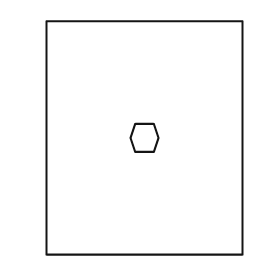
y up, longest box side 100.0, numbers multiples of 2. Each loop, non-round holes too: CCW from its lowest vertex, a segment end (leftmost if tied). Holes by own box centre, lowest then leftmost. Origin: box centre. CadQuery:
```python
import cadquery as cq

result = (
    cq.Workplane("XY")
    .moveTo(-42.0, -50.0)
    .lineTo(42.0, -50.0)
    .lineTo(42.0, 50.0)
    .lineTo(-42.0, 50.0)
    .close()
    .moveTo(-4.0, -6.0)
    .lineTo(4.0, -6.0)
    .lineTo(6.0, 0.0)
    .lineTo(4.0, 6.0)
    .lineTo(-4.0, 6.0)
    .lineTo(-6.0, 0.0)
    .close()
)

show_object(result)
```